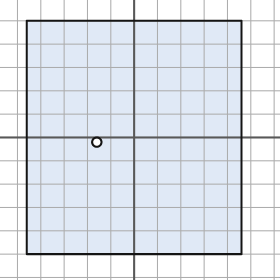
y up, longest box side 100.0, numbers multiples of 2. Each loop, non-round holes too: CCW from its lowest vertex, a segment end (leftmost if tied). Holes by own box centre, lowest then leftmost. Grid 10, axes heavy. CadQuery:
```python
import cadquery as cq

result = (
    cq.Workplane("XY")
    .moveTo(-46.0, -50.0)
    .lineTo(46.0, -50.0)
    .lineTo(46.0, 50.0)
    .lineTo(-46.0, 50.0)
    .close()
    .moveTo(-16.0, -2.0)
    .circle(2.0)
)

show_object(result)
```